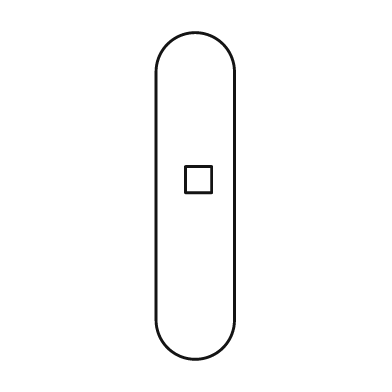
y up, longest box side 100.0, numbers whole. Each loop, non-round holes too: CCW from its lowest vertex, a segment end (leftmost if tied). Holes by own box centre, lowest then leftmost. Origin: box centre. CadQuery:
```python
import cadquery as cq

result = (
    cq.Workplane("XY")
    .moveTo(-12.0, -38.0)
    .threePointArc((0.0, -50.0), (12.0, -38.0))
    .lineTo(12.0, 38.0)
    .threePointArc((0.0, 50.0), (-12.0, 38.0))
    .close()
    .moveTo(-3.0, 1.0)
    .lineTo(5.0, 1.0)
    .lineTo(5.0, 9.0)
    .lineTo(-3.0, 9.0)
    .close()
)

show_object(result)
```